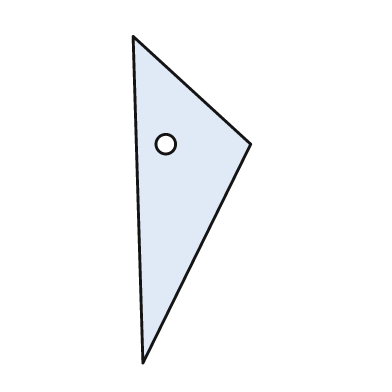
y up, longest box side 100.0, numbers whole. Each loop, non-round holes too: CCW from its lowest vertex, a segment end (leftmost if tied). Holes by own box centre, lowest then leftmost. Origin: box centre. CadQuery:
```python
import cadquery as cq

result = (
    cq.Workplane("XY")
    .moveTo(-15.0, -50.0)
    .lineTo(18.0, 17.0)
    .lineTo(-18.0, 50.0)
    .close()
    .moveTo(-8.0, 17.0)
    .circle(3.0)
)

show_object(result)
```